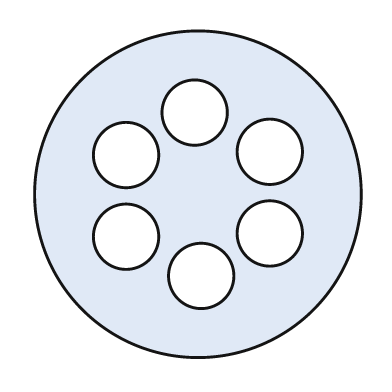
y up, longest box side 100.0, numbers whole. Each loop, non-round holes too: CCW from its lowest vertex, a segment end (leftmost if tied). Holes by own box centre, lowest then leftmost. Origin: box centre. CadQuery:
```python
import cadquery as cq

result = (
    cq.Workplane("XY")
    .moveTo(0.0, 0.0)
    .circle(50.0)
    .moveTo(1.0, -25.0)
    .circle(10.0)
    .moveTo(-22.0, -13.0)
    .circle(10.0)
    .moveTo(22.0, -12.0)
    .circle(10.0)
    .moveTo(-22.0, 12.0)
    .circle(10.0)
    .moveTo(22.0, 13.0)
    .circle(10.0)
    .moveTo(-1.0, 25.0)
    .circle(10.0)
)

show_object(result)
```